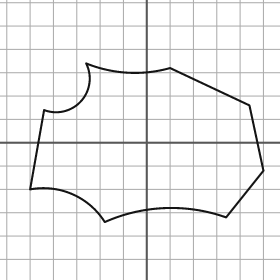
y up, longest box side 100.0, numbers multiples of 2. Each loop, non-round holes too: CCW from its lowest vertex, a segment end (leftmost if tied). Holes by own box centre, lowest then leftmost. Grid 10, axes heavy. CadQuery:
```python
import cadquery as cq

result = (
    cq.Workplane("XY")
    .moveTo(-18.0, -34.0)
    .threePointArc((8.0, -28.0), (34.0, -32.0))
    .lineTo(50.0, -12.0)
    .lineTo(44.0, 16.0)
    .lineTo(10.0, 32.0)
    .threePointArc((-8.0, 30.0), (-26.0, 34.0))
    .threePointArc((-28.0, 18.0), (-44.0, 14.0))
    .lineTo(-50.0, -20.0)
    .threePointArc((-32.0, -22.0), (-18.0, -34.0))
    .close()
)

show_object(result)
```